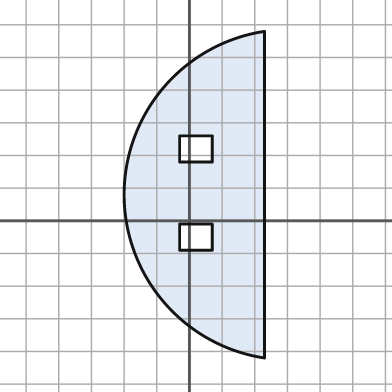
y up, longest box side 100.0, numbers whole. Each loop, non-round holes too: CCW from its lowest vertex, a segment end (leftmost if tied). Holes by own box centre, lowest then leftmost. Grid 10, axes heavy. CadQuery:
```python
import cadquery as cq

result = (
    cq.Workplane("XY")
    .moveTo(23.0, -42.0)
    .lineTo(23.0, 58.0)
    .threePointArc((-20.0, 8.0), (23.0, -42.0))
    .close()
    .moveTo(-3.0, -9.0)
    .lineTo(7.0, -9.0)
    .lineTo(7.0, -1.0)
    .lineTo(-3.0, -1.0)
    .close()
    .moveTo(-3.0, 18.0)
    .lineTo(7.0, 18.0)
    .lineTo(7.0, 26.0)
    .lineTo(-3.0, 26.0)
    .close()
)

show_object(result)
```